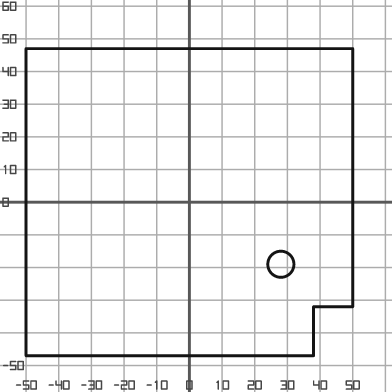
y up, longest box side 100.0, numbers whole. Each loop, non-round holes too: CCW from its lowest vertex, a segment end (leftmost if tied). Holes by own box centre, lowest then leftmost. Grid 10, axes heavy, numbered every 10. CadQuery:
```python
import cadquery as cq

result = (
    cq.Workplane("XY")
    .moveTo(-50.0, -47.0)
    .lineTo(38.0, -47.0)
    .lineTo(38.0, -32.0)
    .lineTo(50.0, -32.0)
    .lineTo(50.0, 47.0)
    .lineTo(-50.0, 47.0)
    .close()
    .moveTo(28.0, -19.0)
    .circle(4.0)
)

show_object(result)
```